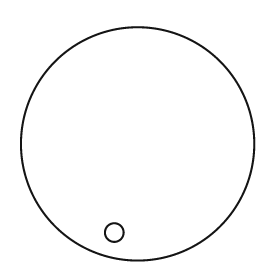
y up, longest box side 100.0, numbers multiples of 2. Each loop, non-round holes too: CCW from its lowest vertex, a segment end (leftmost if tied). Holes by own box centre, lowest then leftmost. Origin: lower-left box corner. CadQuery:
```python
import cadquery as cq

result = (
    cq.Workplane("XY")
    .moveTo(50.0, 50.0)
    .circle(50.0)
    .moveTo(40.0, 12.0)
    .circle(4.0)
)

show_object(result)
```